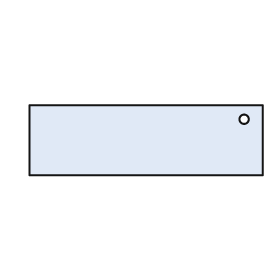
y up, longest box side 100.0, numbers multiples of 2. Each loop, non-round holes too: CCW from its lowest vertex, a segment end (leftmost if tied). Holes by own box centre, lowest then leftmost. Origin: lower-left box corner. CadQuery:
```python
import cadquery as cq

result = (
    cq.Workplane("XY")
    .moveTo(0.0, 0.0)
    .lineTo(100.0, 0.0)
    .lineTo(100.0, 30.0)
    .lineTo(0.0, 30.0)
    .close()
    .moveTo(92.0, 24.0)
    .circle(2.0)
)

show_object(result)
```